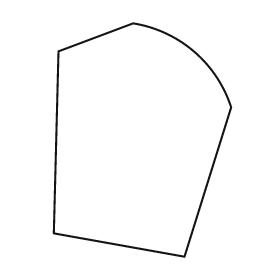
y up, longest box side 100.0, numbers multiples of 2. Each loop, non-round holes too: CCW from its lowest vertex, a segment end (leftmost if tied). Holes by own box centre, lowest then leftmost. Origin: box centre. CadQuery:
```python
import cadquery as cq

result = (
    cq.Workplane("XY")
    .moveTo(18.0, -50.0)
    .lineTo(38.0, 14.0)
    .threePointArc((22.0, 38.0), (-4.0, 50.0))
    .lineTo(-36.0, 38.0)
    .lineTo(-38.0, -40.0)
    .close()
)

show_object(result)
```